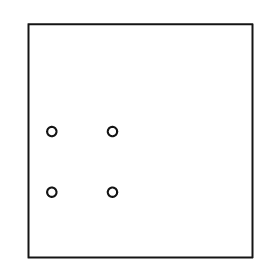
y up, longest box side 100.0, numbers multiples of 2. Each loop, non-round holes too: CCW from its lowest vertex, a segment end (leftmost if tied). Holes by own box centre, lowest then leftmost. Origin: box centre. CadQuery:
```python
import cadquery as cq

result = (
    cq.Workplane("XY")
    .moveTo(-48.0, -50.0)
    .lineTo(48.0, -50.0)
    .lineTo(48.0, 50.0)
    .lineTo(-48.0, 50.0)
    .close()
    .moveTo(-38.0, -22.0)
    .circle(2.0)
    .moveTo(-12.0, -22.0)
    .circle(2.0)
    .moveTo(-38.0, 4.0)
    .circle(2.0)
    .moveTo(-12.0, 4.0)
    .circle(2.0)
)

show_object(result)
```